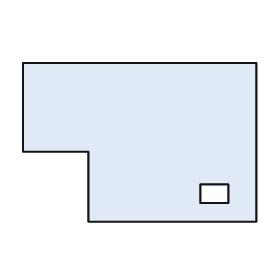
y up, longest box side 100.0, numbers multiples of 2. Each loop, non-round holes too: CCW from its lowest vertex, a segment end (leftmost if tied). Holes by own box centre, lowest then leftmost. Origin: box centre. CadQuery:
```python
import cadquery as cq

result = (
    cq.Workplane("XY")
    .moveTo(-22.0, -34.0)
    .lineTo(50.0, -34.0)
    .lineTo(50.0, 34.0)
    .lineTo(-50.0, 34.0)
    .lineTo(-50.0, -4.0)
    .lineTo(-22.0, -4.0)
    .close()
    .moveTo(26.0, -26.0)
    .lineTo(38.0, -26.0)
    .lineTo(38.0, -18.0)
    .lineTo(26.0, -18.0)
    .close()
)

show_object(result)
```